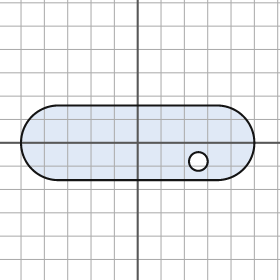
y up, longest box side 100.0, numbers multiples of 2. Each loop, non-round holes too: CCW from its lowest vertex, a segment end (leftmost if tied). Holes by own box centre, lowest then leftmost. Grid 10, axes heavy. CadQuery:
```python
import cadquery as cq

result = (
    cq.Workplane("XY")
    .moveTo(-34.0, -16.0)
    .lineTo(34.0, -16.0)
    .threePointArc((50.0, 0.0), (34.0, 16.0))
    .lineTo(-34.0, 16.0)
    .threePointArc((-50.0, 0.0), (-34.0, -16.0))
    .close()
    .moveTo(26.0, -8.0)
    .circle(4.0)
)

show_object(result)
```